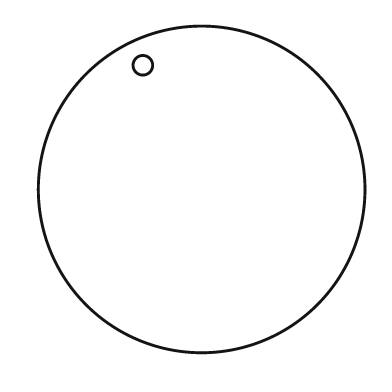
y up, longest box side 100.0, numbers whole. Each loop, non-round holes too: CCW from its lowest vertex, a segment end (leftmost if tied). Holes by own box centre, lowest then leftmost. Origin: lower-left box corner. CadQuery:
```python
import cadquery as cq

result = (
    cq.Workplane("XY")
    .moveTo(50.0, 50.0)
    .circle(50.0)
    .moveTo(32.0, 88.0)
    .circle(3.0)
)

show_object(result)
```